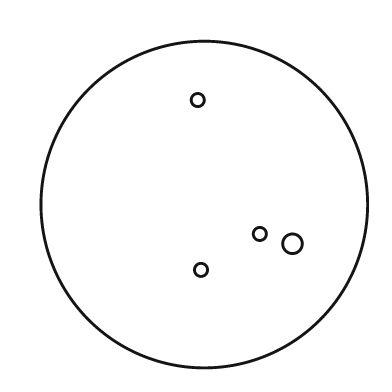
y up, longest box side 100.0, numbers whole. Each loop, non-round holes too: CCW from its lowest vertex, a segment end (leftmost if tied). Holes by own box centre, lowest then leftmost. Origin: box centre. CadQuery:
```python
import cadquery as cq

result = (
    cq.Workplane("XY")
    .moveTo(0.0, 0.0)
    .circle(50.0)
    .moveTo(-1.0, -20.0)
    .circle(2.0)
    .moveTo(27.0, -12.0)
    .circle(3.0)
    .moveTo(17.0, -9.0)
    .circle(2.0)
    .moveTo(-2.0, 32.0)
    .circle(2.0)
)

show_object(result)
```